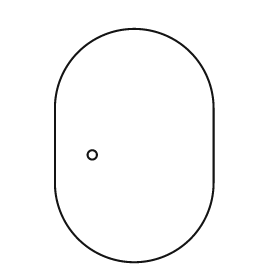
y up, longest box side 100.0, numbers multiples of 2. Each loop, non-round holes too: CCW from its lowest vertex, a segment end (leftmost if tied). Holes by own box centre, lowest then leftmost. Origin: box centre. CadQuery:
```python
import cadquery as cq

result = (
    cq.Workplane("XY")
    .moveTo(-34.0, -16.0)
    .threePointArc((0.0, -50.0), (34.0, -16.0))
    .lineTo(34.0, 16.0)
    .threePointArc((0.0, 50.0), (-34.0, 16.0))
    .close()
    .moveTo(-18.0, -4.0)
    .circle(2.0)
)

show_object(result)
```